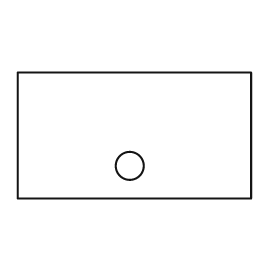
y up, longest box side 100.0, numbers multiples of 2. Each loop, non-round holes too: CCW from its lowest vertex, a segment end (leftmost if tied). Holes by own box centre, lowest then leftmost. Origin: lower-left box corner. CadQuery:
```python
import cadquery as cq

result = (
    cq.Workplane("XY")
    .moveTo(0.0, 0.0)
    .lineTo(100.0, 0.0)
    .lineTo(100.0, 54.0)
    .lineTo(0.0, 54.0)
    .close()
    .moveTo(48.0, 14.0)
    .circle(6.0)
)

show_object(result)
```